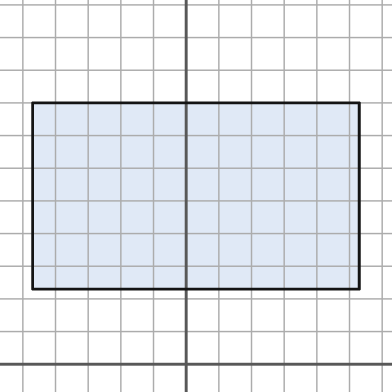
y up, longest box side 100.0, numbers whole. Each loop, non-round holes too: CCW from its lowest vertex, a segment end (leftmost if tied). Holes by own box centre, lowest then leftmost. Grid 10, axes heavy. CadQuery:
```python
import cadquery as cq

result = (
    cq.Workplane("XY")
    .moveTo(-47.0, 23.0)
    .lineTo(53.0, 23.0)
    .lineTo(53.0, 80.0)
    .lineTo(-47.0, 80.0)
    .close()
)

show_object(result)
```